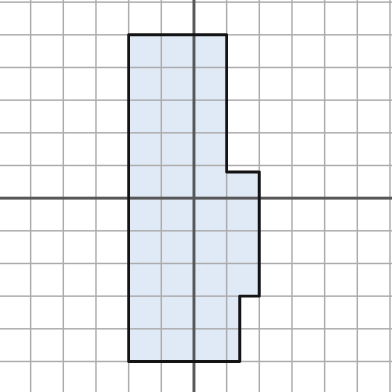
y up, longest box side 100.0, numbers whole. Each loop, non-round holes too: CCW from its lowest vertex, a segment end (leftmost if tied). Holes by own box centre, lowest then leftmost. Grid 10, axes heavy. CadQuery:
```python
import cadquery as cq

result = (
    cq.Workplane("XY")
    .moveTo(-20.0, -50.0)
    .lineTo(14.0, -50.0)
    .lineTo(14.0, -30.0)
    .lineTo(20.0, -30.0)
    .lineTo(20.0, 8.0)
    .lineTo(10.0, 8.0)
    .lineTo(10.0, 50.0)
    .lineTo(-20.0, 50.0)
    .close()
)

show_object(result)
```